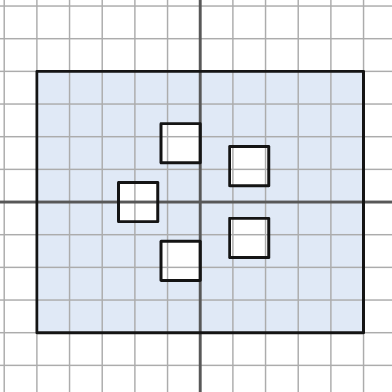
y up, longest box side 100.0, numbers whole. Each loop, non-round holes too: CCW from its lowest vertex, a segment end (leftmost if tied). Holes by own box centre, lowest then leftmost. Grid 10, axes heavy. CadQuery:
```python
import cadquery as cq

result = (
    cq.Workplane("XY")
    .moveTo(-50.0, -40.0)
    .lineTo(50.0, -40.0)
    .lineTo(50.0, 40.0)
    .lineTo(-50.0, 40.0)
    .close()
    .moveTo(-12.0, -24.0)
    .lineTo(0.0, -24.0)
    .lineTo(0.0, -12.0)
    .lineTo(-12.0, -12.0)
    .close()
    .moveTo(9.0, -17.0)
    .lineTo(21.0, -17.0)
    .lineTo(21.0, -5.0)
    .lineTo(9.0, -5.0)
    .close()
    .moveTo(-25.0, -6.0)
    .lineTo(-13.0, -6.0)
    .lineTo(-13.0, 6.0)
    .lineTo(-25.0, 6.0)
    .close()
    .moveTo(9.0, 5.0)
    .lineTo(21.0, 5.0)
    .lineTo(21.0, 17.0)
    .lineTo(9.0, 17.0)
    .close()
    .moveTo(-12.0, 12.0)
    .lineTo(0.0, 12.0)
    .lineTo(0.0, 24.0)
    .lineTo(-12.0, 24.0)
    .close()
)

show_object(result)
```